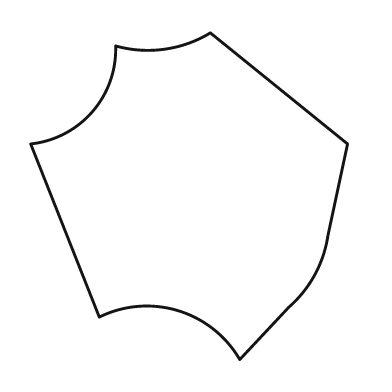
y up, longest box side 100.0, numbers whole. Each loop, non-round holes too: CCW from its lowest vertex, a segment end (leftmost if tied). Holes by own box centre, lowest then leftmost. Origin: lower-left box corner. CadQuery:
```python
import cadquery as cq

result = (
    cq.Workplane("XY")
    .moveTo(64.0, 0.0)
    .lineTo(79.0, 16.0)
    .threePointArc((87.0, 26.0), (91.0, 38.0))
    .lineTo(97.0, 66.0)
    .lineTo(55.0, 100.0)
    .threePointArc((41.0, 95.0), (26.0, 96.0))
    .threePointArc((19.0, 76.0), (0.0, 66.0))
    .lineTo(21.0, 13.0)
    .threePointArc((45.0, 15.0), (64.0, 0.0))
    .close()
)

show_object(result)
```